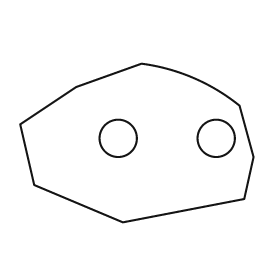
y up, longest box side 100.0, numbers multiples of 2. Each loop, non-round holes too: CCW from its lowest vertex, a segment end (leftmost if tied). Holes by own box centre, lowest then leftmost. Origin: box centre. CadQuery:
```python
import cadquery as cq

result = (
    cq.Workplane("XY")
    .moveTo(-6.0, -34.0)
    .lineTo(46.0, -24.0)
    .lineTo(50.0, -6.0)
    .lineTo(44.0, 16.0)
    .threePointArc((24.0, 28.0), (2.0, 34.0))
    .lineTo(-26.0, 24.0)
    .lineTo(-50.0, 8.0)
    .lineTo(-44.0, -18.0)
    .close()
    .moveTo(-8.0, 2.0)
    .circle(8.0)
    .moveTo(34.0, 2.0)
    .circle(8.0)
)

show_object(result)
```